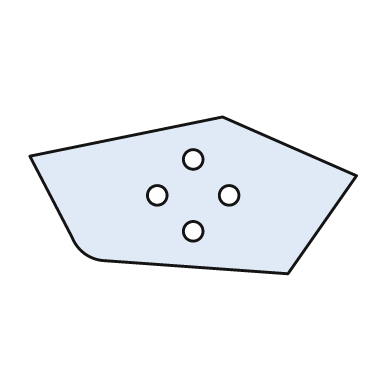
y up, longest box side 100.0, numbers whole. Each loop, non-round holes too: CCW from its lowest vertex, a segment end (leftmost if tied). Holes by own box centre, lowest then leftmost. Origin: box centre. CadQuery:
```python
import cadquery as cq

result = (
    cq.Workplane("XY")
    .moveTo(29.0, -24.0)
    .lineTo(50.0, 6.0)
    .lineTo(9.0, 24.0)
    .lineTo(-50.0, 12.0)
    .lineTo(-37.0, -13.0)
    .threePointArc((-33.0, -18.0), (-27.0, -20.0))
    .close()
    .moveTo(0.0, -11.0)
    .circle(3.0)
    .moveTo(-11.0, 0.0)
    .circle(3.0)
    .moveTo(11.0, 0.0)
    .circle(3.0)
    .moveTo(0.0, 11.0)
    .circle(3.0)
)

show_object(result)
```